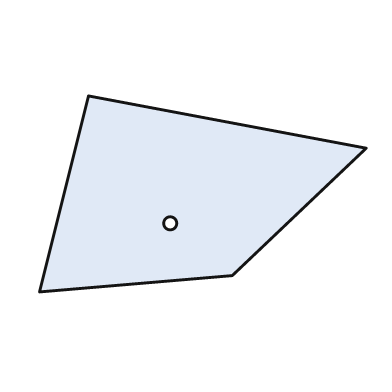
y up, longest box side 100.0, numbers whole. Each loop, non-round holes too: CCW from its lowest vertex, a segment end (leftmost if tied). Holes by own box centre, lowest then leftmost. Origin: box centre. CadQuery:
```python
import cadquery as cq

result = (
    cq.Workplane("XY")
    .moveTo(-50.0, -30.0)
    .lineTo(9.0, -25.0)
    .lineTo(50.0, 14.0)
    .lineTo(-35.0, 30.0)
    .close()
    .moveTo(-10.0, -9.0)
    .circle(2.0)
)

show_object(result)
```